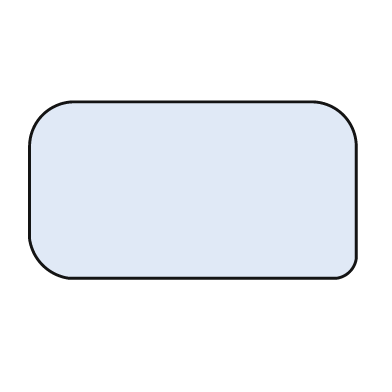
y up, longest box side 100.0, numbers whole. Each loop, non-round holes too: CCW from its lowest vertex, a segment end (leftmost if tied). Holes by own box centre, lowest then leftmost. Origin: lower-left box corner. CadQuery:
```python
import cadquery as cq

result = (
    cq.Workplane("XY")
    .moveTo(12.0, 0.0)
    .lineTo(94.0, 0.0)
    .threePointArc((98.0, 2.0), (100.0, 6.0))
    .lineTo(100.0, 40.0)
    .threePointArc((96.0, 50.0), (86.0, 54.0))
    .lineTo(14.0, 54.0)
    .threePointArc((4.0, 50.0), (0.0, 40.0))
    .lineTo(0.0, 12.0)
    .threePointArc((4.0, 4.0), (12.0, 0.0))
    .close()
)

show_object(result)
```